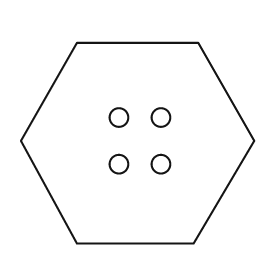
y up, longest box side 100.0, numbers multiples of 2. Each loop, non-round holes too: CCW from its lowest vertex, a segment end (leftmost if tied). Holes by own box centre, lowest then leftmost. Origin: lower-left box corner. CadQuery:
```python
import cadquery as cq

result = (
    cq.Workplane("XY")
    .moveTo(24.0, 0.0)
    .lineTo(74.0, 0.0)
    .lineTo(100.0, 44.0)
    .lineTo(76.0, 86.0)
    .lineTo(24.0, 86.0)
    .lineTo(0.0, 44.0)
    .close()
    .moveTo(42.0, 34.0)
    .circle(4.0)
    .moveTo(60.0, 34.0)
    .circle(4.0)
    .moveTo(42.0, 54.0)
    .circle(4.0)
    .moveTo(60.0, 54.0)
    .circle(4.0)
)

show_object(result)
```